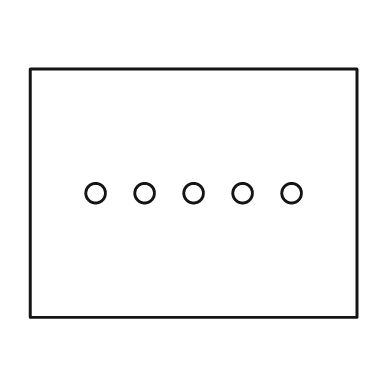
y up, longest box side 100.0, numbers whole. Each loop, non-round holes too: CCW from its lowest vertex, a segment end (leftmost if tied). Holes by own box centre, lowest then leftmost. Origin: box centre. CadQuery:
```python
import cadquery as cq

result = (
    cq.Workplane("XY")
    .moveTo(-50.0, -38.0)
    .lineTo(50.0, -38.0)
    .lineTo(50.0, 38.0)
    .lineTo(-50.0, 38.0)
    .close()
    .moveTo(-30.0, 0.0)
    .circle(3.0)
    .moveTo(-15.0, 0.0)
    .circle(3.0)
    .moveTo(0.0, 0.0)
    .circle(3.0)
    .moveTo(15.0, 0.0)
    .circle(3.0)
    .moveTo(30.0, 0.0)
    .circle(3.0)
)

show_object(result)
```